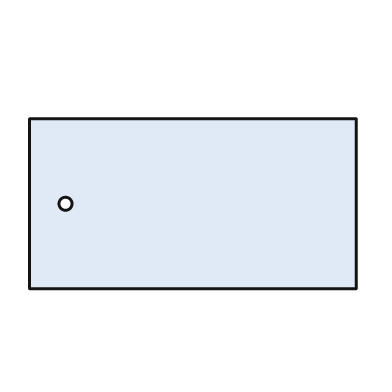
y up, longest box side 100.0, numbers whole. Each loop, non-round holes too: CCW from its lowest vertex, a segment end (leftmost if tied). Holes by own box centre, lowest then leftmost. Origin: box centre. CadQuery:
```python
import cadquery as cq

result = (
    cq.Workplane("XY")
    .moveTo(-50.0, -26.0)
    .lineTo(50.0, -26.0)
    .lineTo(50.0, 26.0)
    .lineTo(-50.0, 26.0)
    .close()
    .moveTo(-39.0, 0.0)
    .circle(2.0)
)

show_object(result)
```